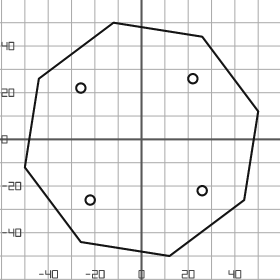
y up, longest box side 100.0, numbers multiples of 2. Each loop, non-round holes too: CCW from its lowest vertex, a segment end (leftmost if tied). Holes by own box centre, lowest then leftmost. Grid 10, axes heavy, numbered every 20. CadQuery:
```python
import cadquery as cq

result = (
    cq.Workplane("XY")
    .moveTo(12.0, -50.0)
    .lineTo(44.0, -26.0)
    .lineTo(50.0, 12.0)
    .lineTo(26.0, 44.0)
    .lineTo(-12.0, 50.0)
    .lineTo(-44.0, 26.0)
    .lineTo(-50.0, -12.0)
    .lineTo(-26.0, -44.0)
    .close()
    .moveTo(-22.0, -26.0)
    .circle(2.0)
    .moveTo(26.0, -22.0)
    .circle(2.0)
    .moveTo(-26.0, 22.0)
    .circle(2.0)
    .moveTo(22.0, 26.0)
    .circle(2.0)
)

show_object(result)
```